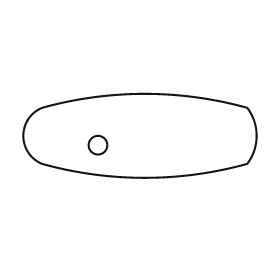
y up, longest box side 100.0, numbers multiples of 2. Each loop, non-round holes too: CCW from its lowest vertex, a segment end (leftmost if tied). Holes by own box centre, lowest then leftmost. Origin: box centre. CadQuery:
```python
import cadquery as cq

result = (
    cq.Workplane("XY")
    .moveTo(-42.0, -12.0)
    .threePointArc((2.0, -18.0), (46.0, -12.0))
    .threePointArc((50.0, 0.0), (46.0, 12.0))
    .threePointArc((2.0, 18.0), (-42.0, 12.0))
    .threePointArc((-50.0, 0.0), (-42.0, -12.0))
    .close()
    .moveTo(-18.0, -4.0)
    .circle(4.0)
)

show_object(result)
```